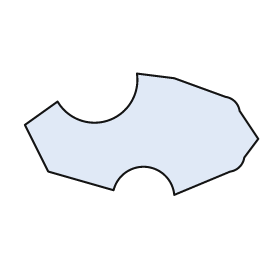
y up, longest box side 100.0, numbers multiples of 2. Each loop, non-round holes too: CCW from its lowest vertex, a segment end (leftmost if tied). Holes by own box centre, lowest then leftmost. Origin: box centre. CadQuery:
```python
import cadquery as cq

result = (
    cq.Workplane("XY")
    .moveTo(14.0, -26.0)
    .lineTo(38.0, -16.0)
    .threePointArc((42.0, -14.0), (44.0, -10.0))
    .lineTo(50.0, -2.0)
    .lineTo(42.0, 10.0)
    .threePointArc((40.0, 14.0), (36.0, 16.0))
    .lineTo(14.0, 24.0)
    .lineTo(-2.0, 26.0)
    .threePointArc((-14.0, 6.0), (-36.0, 14.0))
    .lineTo(-50.0, 4.0)
    .lineTo(-40.0, -16.0)
    .lineTo(-12.0, -24.0)
    .threePointArc((2.0, -14.0), (14.0, -26.0))
    .close()
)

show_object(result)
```